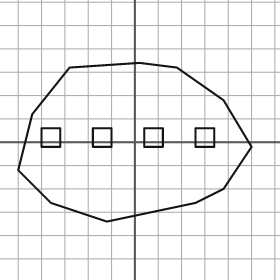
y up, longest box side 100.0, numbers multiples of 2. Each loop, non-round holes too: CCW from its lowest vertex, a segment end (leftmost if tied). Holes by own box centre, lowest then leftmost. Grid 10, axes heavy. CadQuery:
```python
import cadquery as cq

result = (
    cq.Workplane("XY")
    .moveTo(-12.0, -34.0)
    .lineTo(26.0, -26.0)
    .lineTo(38.0, -20.0)
    .lineTo(50.0, -2.0)
    .lineTo(38.0, 18.0)
    .lineTo(18.0, 32.0)
    .lineTo(2.0, 34.0)
    .lineTo(-28.0, 32.0)
    .lineTo(-44.0, 12.0)
    .lineTo(-50.0, -12.0)
    .lineTo(-36.0, -26.0)
    .close()
    .moveTo(-40.0, -2.0)
    .lineTo(-32.0, -2.0)
    .lineTo(-32.0, 6.0)
    .lineTo(-40.0, 6.0)
    .close()
    .moveTo(-18.0, -2.0)
    .lineTo(-10.0, -2.0)
    .lineTo(-10.0, 6.0)
    .lineTo(-18.0, 6.0)
    .close()
    .moveTo(4.0, -2.0)
    .lineTo(12.0, -2.0)
    .lineTo(12.0, 6.0)
    .lineTo(4.0, 6.0)
    .close()
    .moveTo(26.0, -2.0)
    .lineTo(34.0, -2.0)
    .lineTo(34.0, 6.0)
    .lineTo(26.0, 6.0)
    .close()
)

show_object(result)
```